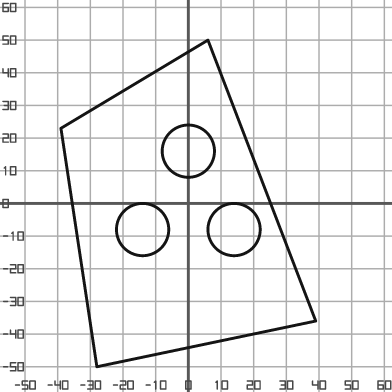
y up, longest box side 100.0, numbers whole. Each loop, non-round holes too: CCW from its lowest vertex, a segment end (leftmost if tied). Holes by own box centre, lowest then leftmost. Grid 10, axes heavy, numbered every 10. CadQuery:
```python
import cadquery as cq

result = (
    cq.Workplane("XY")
    .moveTo(-28.0, -50.0)
    .lineTo(39.0, -36.0)
    .lineTo(6.0, 50.0)
    .lineTo(-39.0, 23.0)
    .close()
    .moveTo(-14.0, -8.0)
    .circle(8.0)
    .moveTo(14.0, -8.0)
    .circle(8.0)
    .moveTo(0.0, 16.0)
    .circle(8.0)
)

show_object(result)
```